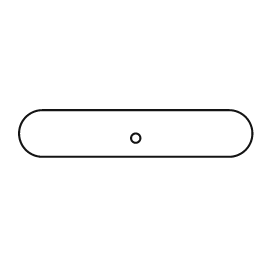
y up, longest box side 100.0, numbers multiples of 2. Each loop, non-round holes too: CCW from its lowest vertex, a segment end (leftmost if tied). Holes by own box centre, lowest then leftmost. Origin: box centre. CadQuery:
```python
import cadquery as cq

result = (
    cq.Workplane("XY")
    .moveTo(-40.0, -10.0)
    .lineTo(40.0, -10.0)
    .threePointArc((50.0, 0.0), (40.0, 10.0))
    .lineTo(-40.0, 10.0)
    .threePointArc((-50.0, 0.0), (-40.0, -10.0))
    .close()
    .moveTo(0.0, -2.0)
    .circle(2.0)
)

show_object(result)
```